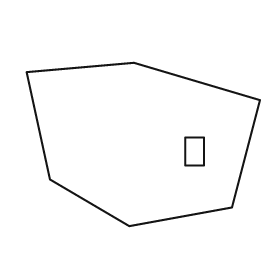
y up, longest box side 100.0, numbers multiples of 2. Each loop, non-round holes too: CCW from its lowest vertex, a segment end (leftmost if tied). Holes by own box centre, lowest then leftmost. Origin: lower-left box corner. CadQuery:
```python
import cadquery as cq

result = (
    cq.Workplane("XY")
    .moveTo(44.0, 0.0)
    .lineTo(88.0, 8.0)
    .lineTo(100.0, 54.0)
    .lineTo(46.0, 70.0)
    .lineTo(0.0, 66.0)
    .lineTo(10.0, 20.0)
    .close()
    .moveTo(68.0, 26.0)
    .lineTo(76.0, 26.0)
    .lineTo(76.0, 38.0)
    .lineTo(68.0, 38.0)
    .close()
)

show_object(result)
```